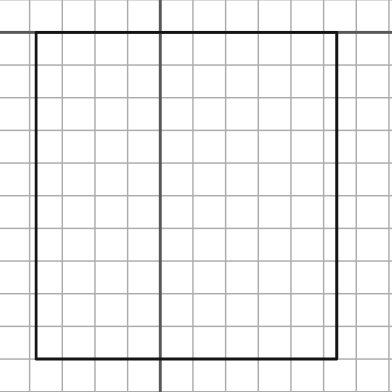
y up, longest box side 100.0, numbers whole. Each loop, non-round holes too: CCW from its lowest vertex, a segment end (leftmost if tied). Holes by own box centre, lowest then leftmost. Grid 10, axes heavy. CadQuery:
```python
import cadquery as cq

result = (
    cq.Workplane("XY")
    .moveTo(-38.0, -100.0)
    .lineTo(54.0, -100.0)
    .lineTo(54.0, 0.0)
    .lineTo(-38.0, 0.0)
    .close()
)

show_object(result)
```